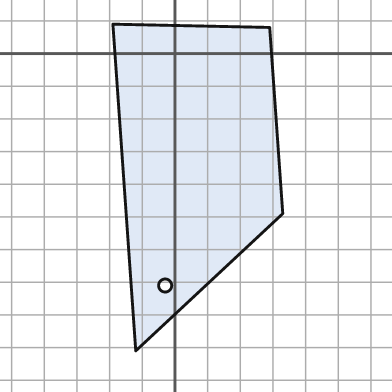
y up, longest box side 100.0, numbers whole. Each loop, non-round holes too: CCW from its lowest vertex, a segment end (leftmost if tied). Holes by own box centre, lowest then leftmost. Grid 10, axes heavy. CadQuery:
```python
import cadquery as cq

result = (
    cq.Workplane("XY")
    .moveTo(-12.0, -91.0)
    .lineTo(33.0, -49.0)
    .lineTo(29.0, 8.0)
    .lineTo(-19.0, 9.0)
    .close()
    .moveTo(-3.0, -71.0)
    .circle(2.0)
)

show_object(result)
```